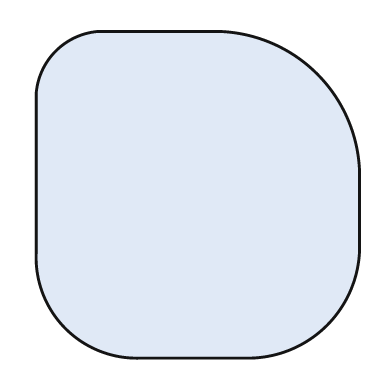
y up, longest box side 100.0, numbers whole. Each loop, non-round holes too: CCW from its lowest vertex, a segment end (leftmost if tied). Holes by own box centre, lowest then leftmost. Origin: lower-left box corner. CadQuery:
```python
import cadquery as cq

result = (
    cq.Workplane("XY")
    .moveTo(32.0, 0.0)
    .lineTo(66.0, 0.0)
    .threePointArc((89.0, 10.0), (99.0, 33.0))
    .lineTo(99.0, 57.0)
    .threePointArc((86.0, 87.0), (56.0, 100.0))
    .lineTo(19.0, 100.0)
    .threePointArc((6.0, 94.0), (0.0, 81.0))
    .lineTo(0.0, 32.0)
    .threePointArc((9.0, 9.0), (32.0, 0.0))
    .close()
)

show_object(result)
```